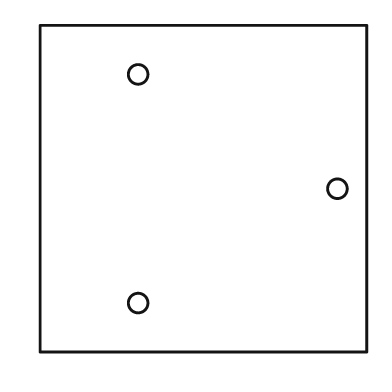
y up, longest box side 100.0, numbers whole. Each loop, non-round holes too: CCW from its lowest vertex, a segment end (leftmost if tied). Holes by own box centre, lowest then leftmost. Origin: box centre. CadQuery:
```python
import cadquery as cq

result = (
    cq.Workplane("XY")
    .moveTo(-50.0, -50.0)
    .lineTo(50.0, -50.0)
    .lineTo(50.0, 50.0)
    .lineTo(-50.0, 50.0)
    .close()
    .moveTo(-20.0, -35.0)
    .circle(3.0)
    .moveTo(41.0, 0.0)
    .circle(3.0)
    .moveTo(-20.0, 35.0)
    .circle(3.0)
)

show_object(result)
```